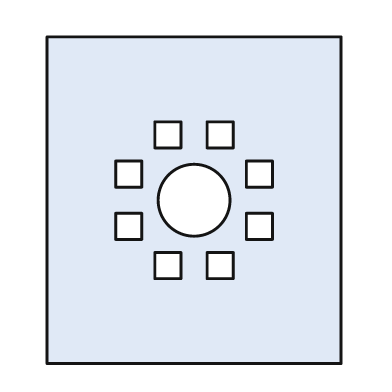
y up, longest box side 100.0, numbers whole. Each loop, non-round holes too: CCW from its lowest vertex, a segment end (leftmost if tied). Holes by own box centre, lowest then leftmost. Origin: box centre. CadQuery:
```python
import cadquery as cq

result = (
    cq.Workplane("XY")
    .moveTo(-45.0, -50.0)
    .lineTo(45.0, -50.0)
    .lineTo(45.0, 50.0)
    .lineTo(-45.0, 50.0)
    .close()
    .moveTo(-12.0, -24.0)
    .lineTo(-4.0, -24.0)
    .lineTo(-4.0, -16.0)
    .lineTo(-12.0, -16.0)
    .close()
    .moveTo(4.0, -24.0)
    .lineTo(12.0, -24.0)
    .lineTo(12.0, -16.0)
    .lineTo(4.0, -16.0)
    .close()
    .moveTo(-24.0, -12.0)
    .lineTo(-16.0, -12.0)
    .lineTo(-16.0, -4.0)
    .lineTo(-24.0, -4.0)
    .close()
    .moveTo(16.0, -12.0)
    .lineTo(24.0, -12.0)
    .lineTo(24.0, -4.0)
    .lineTo(16.0, -4.0)
    .close()
    .moveTo(0.0, 0.0)
    .circle(11.0)
    .moveTo(-24.0, 4.0)
    .lineTo(-16.0, 4.0)
    .lineTo(-16.0, 12.0)
    .lineTo(-24.0, 12.0)
    .close()
    .moveTo(16.0, 4.0)
    .lineTo(24.0, 4.0)
    .lineTo(24.0, 12.0)
    .lineTo(16.0, 12.0)
    .close()
    .moveTo(-12.0, 16.0)
    .lineTo(-4.0, 16.0)
    .lineTo(-4.0, 24.0)
    .lineTo(-12.0, 24.0)
    .close()
    .moveTo(4.0, 16.0)
    .lineTo(12.0, 16.0)
    .lineTo(12.0, 24.0)
    .lineTo(4.0, 24.0)
    .close()
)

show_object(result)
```